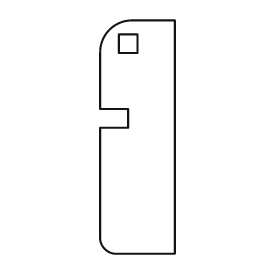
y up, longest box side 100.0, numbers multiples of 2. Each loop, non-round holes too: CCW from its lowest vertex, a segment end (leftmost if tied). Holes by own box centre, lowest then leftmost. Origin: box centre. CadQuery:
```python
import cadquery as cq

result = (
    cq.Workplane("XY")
    .moveTo(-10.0, -50.0)
    .lineTo(16.0, -50.0)
    .lineTo(16.0, 50.0)
    .lineTo(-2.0, 50.0)
    .threePointArc((-12.0, 46.0), (-16.0, 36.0))
    .lineTo(-16.0, 12.0)
    .lineTo(-4.0, 12.0)
    .lineTo(-4.0, 4.0)
    .lineTo(-16.0, 4.0)
    .lineTo(-16.0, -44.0)
    .threePointArc((-14.0, -48.0), (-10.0, -50.0))
    .close()
    .moveTo(-8.0, 36.0)
    .lineTo(0.0, 36.0)
    .lineTo(0.0, 44.0)
    .lineTo(-8.0, 44.0)
    .close()
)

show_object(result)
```